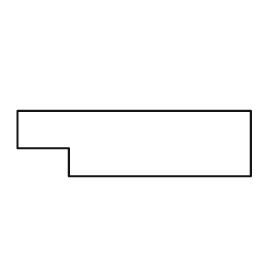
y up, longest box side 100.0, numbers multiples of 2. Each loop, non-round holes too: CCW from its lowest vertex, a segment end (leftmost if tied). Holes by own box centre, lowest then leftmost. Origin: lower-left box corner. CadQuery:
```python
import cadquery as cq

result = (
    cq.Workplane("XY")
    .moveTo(22.0, 0.0)
    .lineTo(100.0, 0.0)
    .lineTo(100.0, 28.0)
    .lineTo(0.0, 28.0)
    .lineTo(0.0, 12.0)
    .lineTo(22.0, 12.0)
    .close()
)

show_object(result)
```